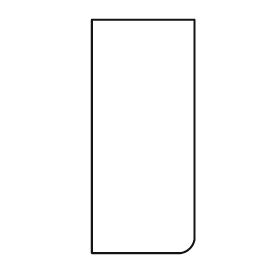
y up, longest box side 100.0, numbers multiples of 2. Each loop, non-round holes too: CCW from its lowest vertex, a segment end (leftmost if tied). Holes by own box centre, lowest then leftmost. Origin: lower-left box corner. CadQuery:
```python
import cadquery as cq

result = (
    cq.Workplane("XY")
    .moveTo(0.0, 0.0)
    .lineTo(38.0, 0.0)
    .threePointArc((42.0, 2.0), (44.0, 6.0))
    .lineTo(44.0, 100.0)
    .lineTo(0.0, 100.0)
    .close()
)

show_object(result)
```